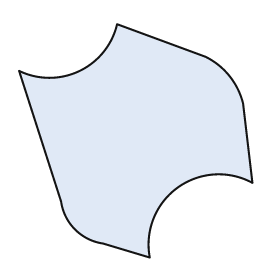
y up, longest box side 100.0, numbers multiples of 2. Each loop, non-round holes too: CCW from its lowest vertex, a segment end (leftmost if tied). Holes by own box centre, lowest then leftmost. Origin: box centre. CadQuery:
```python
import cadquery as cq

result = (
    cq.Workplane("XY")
    .moveTo(6.0, -50.0)
    .threePointArc((18.0, -20.0), (50.0, -18.0))
    .lineTo(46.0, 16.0)
    .threePointArc((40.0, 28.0), (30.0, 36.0))
    .lineTo(-8.0, 50.0)
    .threePointArc((-24.0, 30.0), (-50.0, 30.0))
    .lineTo(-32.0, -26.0)
    .threePointArc((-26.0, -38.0), (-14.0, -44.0))
    .close()
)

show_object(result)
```